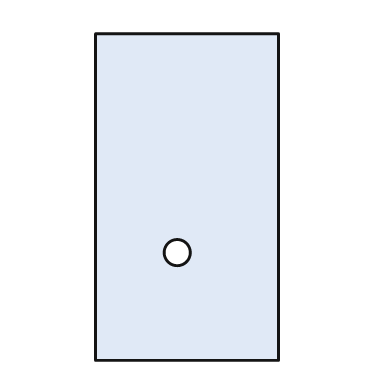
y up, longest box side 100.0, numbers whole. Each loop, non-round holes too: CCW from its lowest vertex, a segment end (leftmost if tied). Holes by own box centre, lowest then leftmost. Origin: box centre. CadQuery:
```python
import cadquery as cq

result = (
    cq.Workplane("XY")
    .moveTo(-28.0, -50.0)
    .lineTo(28.0, -50.0)
    .lineTo(28.0, 50.0)
    .lineTo(-28.0, 50.0)
    .close()
    .moveTo(-3.0, -17.0)
    .circle(4.0)
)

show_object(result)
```